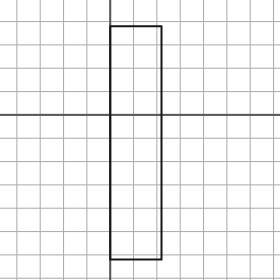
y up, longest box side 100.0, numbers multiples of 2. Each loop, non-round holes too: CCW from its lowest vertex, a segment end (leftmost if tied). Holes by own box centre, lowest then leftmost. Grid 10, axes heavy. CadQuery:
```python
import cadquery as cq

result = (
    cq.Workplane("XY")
    .moveTo(0.0, -62.0)
    .lineTo(22.0, -62.0)
    .lineTo(22.0, 38.0)
    .lineTo(0.0, 38.0)
    .close()
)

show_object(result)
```